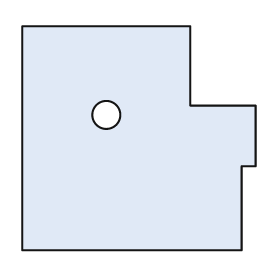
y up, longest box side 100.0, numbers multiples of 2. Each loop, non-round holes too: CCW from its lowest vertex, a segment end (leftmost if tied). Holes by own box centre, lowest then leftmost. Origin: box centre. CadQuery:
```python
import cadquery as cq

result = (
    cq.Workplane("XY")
    .moveTo(-50.0, -48.0)
    .lineTo(44.0, -48.0)
    .lineTo(44.0, -12.0)
    .lineTo(50.0, -12.0)
    .lineTo(50.0, 14.0)
    .lineTo(22.0, 14.0)
    .lineTo(22.0, 48.0)
    .lineTo(-50.0, 48.0)
    .close()
    .moveTo(-14.0, 10.0)
    .circle(6.0)
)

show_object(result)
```